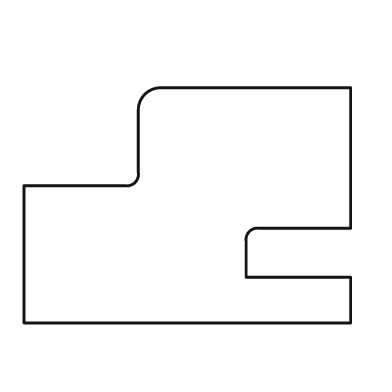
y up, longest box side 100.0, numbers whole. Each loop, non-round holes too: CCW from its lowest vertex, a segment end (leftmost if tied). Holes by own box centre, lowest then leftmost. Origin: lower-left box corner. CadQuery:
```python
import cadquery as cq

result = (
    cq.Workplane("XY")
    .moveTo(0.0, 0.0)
    .lineTo(100.0, 0.0)
    .lineTo(100.0, 14.0)
    .lineTo(68.0, 14.0)
    .lineTo(68.0, 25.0)
    .threePointArc((69.0, 28.0), (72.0, 29.0))
    .lineTo(100.0, 29.0)
    .lineTo(100.0, 72.0)
    .lineTo(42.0, 72.0)
    .threePointArc((37.0, 70.0), (35.0, 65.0))
    .lineTo(35.0, 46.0)
    .threePointArc((34.0, 43.0), (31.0, 42.0))
    .lineTo(0.0, 42.0)
    .close()
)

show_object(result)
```